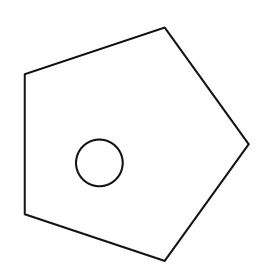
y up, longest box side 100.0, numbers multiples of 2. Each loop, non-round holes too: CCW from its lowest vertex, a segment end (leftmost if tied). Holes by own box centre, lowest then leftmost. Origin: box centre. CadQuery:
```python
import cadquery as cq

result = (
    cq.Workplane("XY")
    .moveTo(12.0, -50.0)
    .lineTo(48.0, 0.0)
    .lineTo(12.0, 50.0)
    .lineTo(-48.0, 30.0)
    .lineTo(-48.0, -30.0)
    .close()
    .moveTo(-16.0, -8.0)
    .circle(10.0)
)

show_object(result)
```